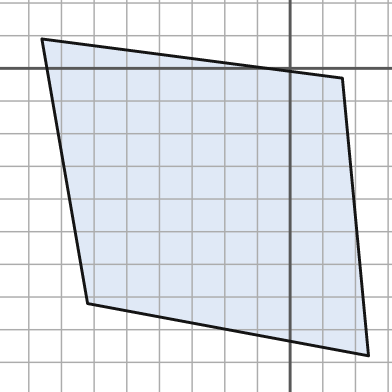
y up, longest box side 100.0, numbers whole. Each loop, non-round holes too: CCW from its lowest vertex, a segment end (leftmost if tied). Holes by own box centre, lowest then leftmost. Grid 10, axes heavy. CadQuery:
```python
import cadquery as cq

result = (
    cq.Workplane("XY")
    .moveTo(24.0, -88.0)
    .lineTo(16.0, -3.0)
    .lineTo(-76.0, 9.0)
    .lineTo(-62.0, -72.0)
    .close()
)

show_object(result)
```